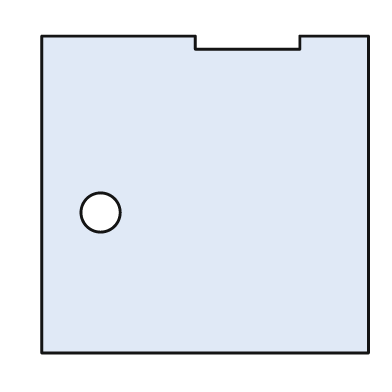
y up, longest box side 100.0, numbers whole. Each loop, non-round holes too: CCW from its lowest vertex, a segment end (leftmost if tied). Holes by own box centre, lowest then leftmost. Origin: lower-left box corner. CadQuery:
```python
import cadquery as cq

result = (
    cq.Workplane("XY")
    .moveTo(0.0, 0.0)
    .lineTo(100.0, 0.0)
    .lineTo(100.0, 97.0)
    .lineTo(79.0, 97.0)
    .lineTo(79.0, 93.0)
    .lineTo(47.0, 93.0)
    .lineTo(47.0, 97.0)
    .lineTo(0.0, 97.0)
    .close()
    .moveTo(18.0, 43.0)
    .circle(6.0)
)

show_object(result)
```